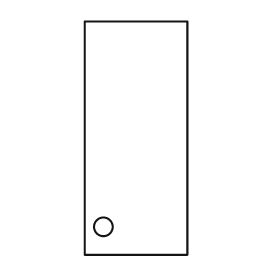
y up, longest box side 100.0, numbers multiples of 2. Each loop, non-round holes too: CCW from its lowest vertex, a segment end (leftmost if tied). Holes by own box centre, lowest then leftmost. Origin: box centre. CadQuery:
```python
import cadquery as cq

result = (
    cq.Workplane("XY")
    .moveTo(-22.0, -50.0)
    .lineTo(22.0, -50.0)
    .lineTo(22.0, 50.0)
    .lineTo(-22.0, 50.0)
    .close()
    .moveTo(-14.0, -38.0)
    .circle(4.0)
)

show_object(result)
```